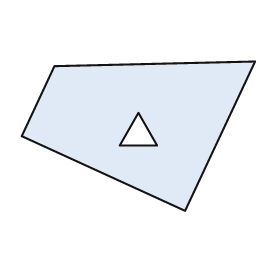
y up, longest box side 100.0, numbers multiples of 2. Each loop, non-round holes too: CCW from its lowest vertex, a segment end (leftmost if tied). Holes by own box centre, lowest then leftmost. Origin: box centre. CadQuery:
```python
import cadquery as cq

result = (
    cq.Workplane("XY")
    .moveTo(20.0, -32.0)
    .lineTo(50.0, 32.0)
    .lineTo(-36.0, 30.0)
    .lineTo(-50.0, 0.0)
    .close()
    .moveTo(-8.0, -4.0)
    .lineTo(8.0, -4.0)
    .lineTo(0.0, 10.0)
    .close()
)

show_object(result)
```